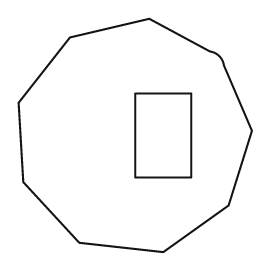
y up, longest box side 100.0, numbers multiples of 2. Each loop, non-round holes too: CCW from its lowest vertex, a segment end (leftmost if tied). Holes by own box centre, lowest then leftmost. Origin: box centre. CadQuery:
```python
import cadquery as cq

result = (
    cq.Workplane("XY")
    .moveTo(12.0, -50.0)
    .lineTo(40.0, -30.0)
    .lineTo(50.0, 2.0)
    .lineTo(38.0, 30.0)
    .threePointArc((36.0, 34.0), (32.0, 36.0))
    .lineTo(6.0, 50.0)
    .lineTo(-28.0, 42.0)
    .lineTo(-50.0, 14.0)
    .lineTo(-48.0, -20.0)
    .lineTo(-24.0, -46.0)
    .close()
    .moveTo(0.0, -18.0)
    .lineTo(24.0, -18.0)
    .lineTo(24.0, 18.0)
    .lineTo(0.0, 18.0)
    .close()
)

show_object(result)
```